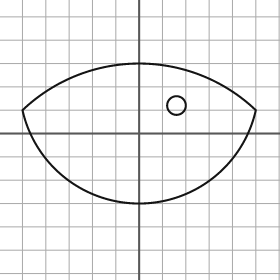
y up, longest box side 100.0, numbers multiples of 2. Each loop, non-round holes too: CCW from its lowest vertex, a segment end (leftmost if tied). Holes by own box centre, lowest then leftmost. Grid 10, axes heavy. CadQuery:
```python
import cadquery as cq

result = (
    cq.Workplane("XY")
    .moveTo(-50.0, 10.0)
    .threePointArc((0.0, -30.0), (50.0, 10.0))
    .threePointArc((0.0, 30.0), (-50.0, 10.0))
    .close()
    .moveTo(16.0, 12.0)
    .circle(4.0)
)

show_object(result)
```